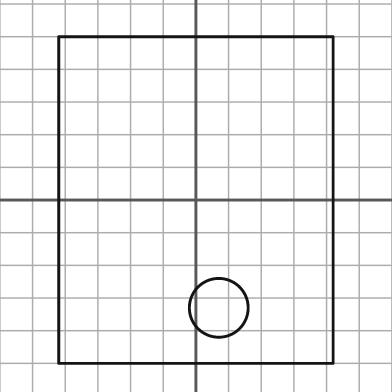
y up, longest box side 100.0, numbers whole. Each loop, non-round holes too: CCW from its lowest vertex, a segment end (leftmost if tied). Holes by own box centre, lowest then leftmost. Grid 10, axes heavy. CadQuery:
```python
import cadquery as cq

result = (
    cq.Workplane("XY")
    .moveTo(-42.0, -50.0)
    .lineTo(42.0, -50.0)
    .lineTo(42.0, 50.0)
    .lineTo(-42.0, 50.0)
    .close()
    .moveTo(7.0, -33.0)
    .circle(9.0)
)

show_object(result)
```